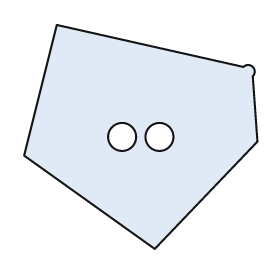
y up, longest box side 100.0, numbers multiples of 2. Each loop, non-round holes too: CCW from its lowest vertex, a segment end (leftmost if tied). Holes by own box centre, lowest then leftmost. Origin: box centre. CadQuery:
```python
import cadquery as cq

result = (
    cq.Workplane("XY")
    .moveTo(6.0, -48.0)
    .lineTo(50.0, -2.0)
    .lineTo(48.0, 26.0)
    .threePointArc((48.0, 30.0), (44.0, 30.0))
    .lineTo(-36.0, 48.0)
    .lineTo(-50.0, -8.0)
    .close()
    .moveTo(-8.0, 0.0)
    .circle(6.0)
    .moveTo(8.0, 0.0)
    .circle(6.0)
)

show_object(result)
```